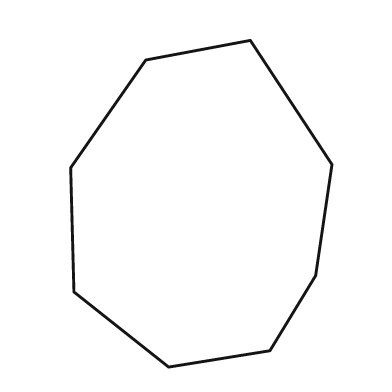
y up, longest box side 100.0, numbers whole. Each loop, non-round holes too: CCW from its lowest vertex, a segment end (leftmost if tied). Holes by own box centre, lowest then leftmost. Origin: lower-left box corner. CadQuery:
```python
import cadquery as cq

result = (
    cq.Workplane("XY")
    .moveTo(30.0, 0.0)
    .lineTo(61.0, 5.0)
    .lineTo(75.0, 28.0)
    .lineTo(80.0, 62.0)
    .lineTo(55.0, 100.0)
    .lineTo(23.0, 94.0)
    .lineTo(0.0, 61.0)
    .lineTo(1.0, 23.0)
    .close()
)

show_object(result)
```